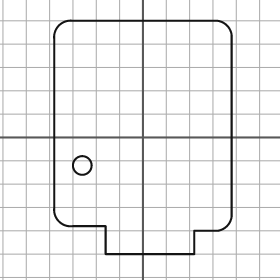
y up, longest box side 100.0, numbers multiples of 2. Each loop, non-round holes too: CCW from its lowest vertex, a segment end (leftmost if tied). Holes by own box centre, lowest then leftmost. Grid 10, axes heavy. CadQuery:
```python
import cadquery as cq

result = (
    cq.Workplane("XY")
    .moveTo(-16.0, -50.0)
    .lineTo(22.0, -50.0)
    .lineTo(22.0, -40.0)
    .lineTo(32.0, -40.0)
    .threePointArc((36.0, -38.0), (38.0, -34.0))
    .lineTo(38.0, 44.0)
    .threePointArc((36.0, 48.0), (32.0, 50.0))
    .lineTo(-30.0, 50.0)
    .threePointArc((-36.0, 48.0), (-38.0, 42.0))
    .lineTo(-38.0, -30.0)
    .threePointArc((-36.0, -36.0), (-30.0, -38.0))
    .lineTo(-16.0, -38.0)
    .close()
    .moveTo(-26.0, -12.0)
    .circle(4.0)
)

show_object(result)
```